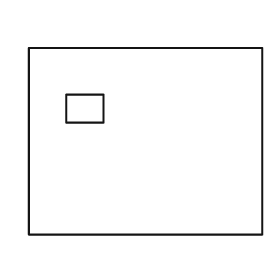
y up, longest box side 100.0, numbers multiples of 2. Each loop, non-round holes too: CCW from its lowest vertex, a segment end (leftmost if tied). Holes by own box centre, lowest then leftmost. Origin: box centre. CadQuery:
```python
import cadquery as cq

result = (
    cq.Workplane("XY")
    .moveTo(-50.0, -40.0)
    .lineTo(50.0, -40.0)
    .lineTo(50.0, 40.0)
    .lineTo(-50.0, 40.0)
    .close()
    .moveTo(-34.0, 8.0)
    .lineTo(-18.0, 8.0)
    .lineTo(-18.0, 20.0)
    .lineTo(-34.0, 20.0)
    .close()
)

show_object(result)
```